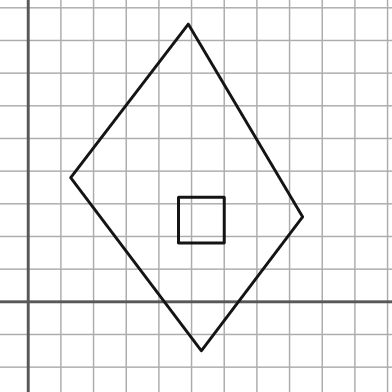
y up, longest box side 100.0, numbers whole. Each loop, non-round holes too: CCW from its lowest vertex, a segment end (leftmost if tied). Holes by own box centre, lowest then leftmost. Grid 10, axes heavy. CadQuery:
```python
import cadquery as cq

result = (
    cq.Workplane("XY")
    .moveTo(53.0, -15.0)
    .lineTo(84.0, 26.0)
    .lineTo(49.0, 85.0)
    .lineTo(13.0, 38.0)
    .close()
    .moveTo(46.0, 18.0)
    .lineTo(60.0, 18.0)
    .lineTo(60.0, 32.0)
    .lineTo(46.0, 32.0)
    .close()
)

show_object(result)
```